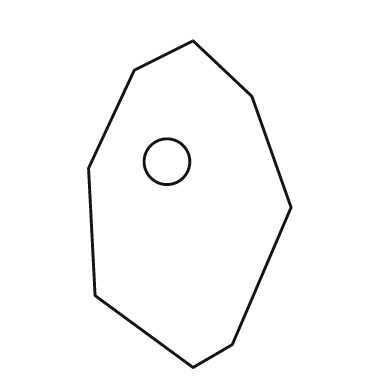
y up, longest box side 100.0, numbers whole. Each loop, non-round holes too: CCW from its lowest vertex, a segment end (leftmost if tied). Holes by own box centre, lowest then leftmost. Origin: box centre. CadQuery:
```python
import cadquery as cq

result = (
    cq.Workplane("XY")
    .moveTo(1.0, -50.0)
    .lineTo(13.0, -43.0)
    .lineTo(31.0, -1.0)
    .lineTo(19.0, 33.0)
    .lineTo(1.0, 50.0)
    .lineTo(-17.0, 41.0)
    .lineTo(-31.0, 11.0)
    .lineTo(-29.0, -28.0)
    .close()
    .moveTo(-7.0, 13.0)
    .circle(7.0)
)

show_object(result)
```